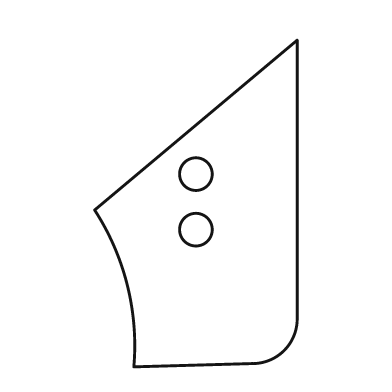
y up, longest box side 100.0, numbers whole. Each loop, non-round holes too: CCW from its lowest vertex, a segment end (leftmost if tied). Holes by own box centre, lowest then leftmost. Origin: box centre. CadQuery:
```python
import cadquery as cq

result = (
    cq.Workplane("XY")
    .moveTo(-19.0, -50.0)
    .lineTo(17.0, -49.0)
    .threePointArc((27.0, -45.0), (31.0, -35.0))
    .lineTo(31.0, 50.0)
    .lineTo(-31.0, -2.0)
    .threePointArc((-21.0, -25.0), (-19.0, -50.0))
    .close()
    .moveTo(0.0, -8.0)
    .circle(5.0)
    .moveTo(0.0, 9.0)
    .circle(5.0)
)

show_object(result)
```